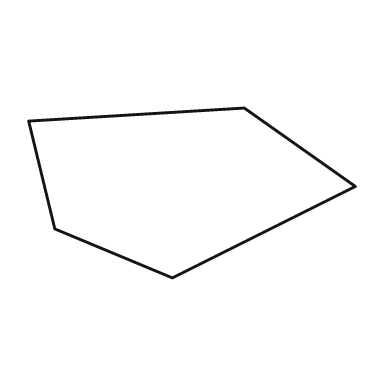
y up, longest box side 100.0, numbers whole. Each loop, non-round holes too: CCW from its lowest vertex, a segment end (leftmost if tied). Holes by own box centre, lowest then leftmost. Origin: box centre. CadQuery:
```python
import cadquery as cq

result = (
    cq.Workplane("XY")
    .moveTo(-6.0, -26.0)
    .lineTo(50.0, 2.0)
    .lineTo(16.0, 26.0)
    .lineTo(-50.0, 22.0)
    .lineTo(-42.0, -11.0)
    .close()
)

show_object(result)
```